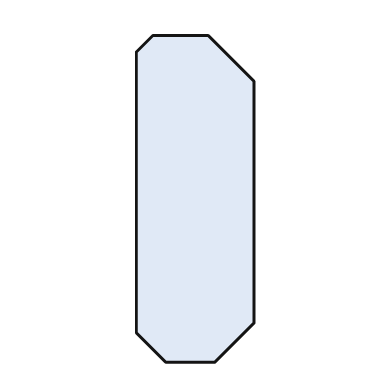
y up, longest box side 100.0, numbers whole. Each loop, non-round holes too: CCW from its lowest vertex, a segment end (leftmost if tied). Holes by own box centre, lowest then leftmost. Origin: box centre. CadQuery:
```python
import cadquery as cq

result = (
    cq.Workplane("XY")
    .moveTo(-9.0, -50.0)
    .lineTo(6.0, -50.0)
    .lineTo(18.0, -38.0)
    .lineTo(18.0, 36.0)
    .lineTo(4.0, 50.0)
    .lineTo(-13.0, 50.0)
    .lineTo(-18.0, 45.0)
    .lineTo(-18.0, -41.0)
    .close()
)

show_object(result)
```